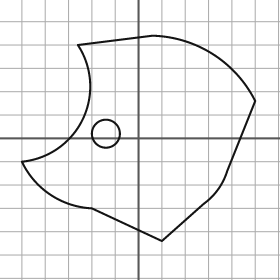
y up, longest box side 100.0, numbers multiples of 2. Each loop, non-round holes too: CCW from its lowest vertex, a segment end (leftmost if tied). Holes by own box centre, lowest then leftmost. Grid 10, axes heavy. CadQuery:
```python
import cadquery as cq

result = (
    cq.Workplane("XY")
    .moveTo(10.0, -44.0)
    .lineTo(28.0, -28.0)
    .threePointArc((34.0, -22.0), (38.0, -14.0))
    .lineTo(50.0, 16.0)
    .threePointArc((32.0, 36.0), (6.0, 44.0))
    .lineTo(-26.0, 40.0)
    .threePointArc((-24.0, 8.0), (-50.0, -10.0))
    .threePointArc((-38.0, -24.0), (-20.0, -30.0))
    .close()
    .moveTo(-14.0, 2.0)
    .circle(6.0)
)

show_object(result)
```